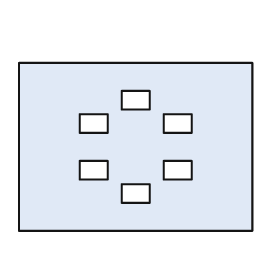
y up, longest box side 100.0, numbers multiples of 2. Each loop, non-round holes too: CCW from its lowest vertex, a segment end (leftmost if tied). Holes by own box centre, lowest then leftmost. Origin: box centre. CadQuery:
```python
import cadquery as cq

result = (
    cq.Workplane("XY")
    .moveTo(-50.0, -36.0)
    .lineTo(50.0, -36.0)
    .lineTo(50.0, 36.0)
    .lineTo(-50.0, 36.0)
    .close()
    .moveTo(-6.0, -24.0)
    .lineTo(6.0, -24.0)
    .lineTo(6.0, -16.0)
    .lineTo(-6.0, -16.0)
    .close()
    .moveTo(-24.0, -14.0)
    .lineTo(-12.0, -14.0)
    .lineTo(-12.0, -6.0)
    .lineTo(-24.0, -6.0)
    .close()
    .moveTo(12.0, -14.0)
    .lineTo(24.0, -14.0)
    .lineTo(24.0, -6.0)
    .lineTo(12.0, -6.0)
    .close()
    .moveTo(-24.0, 6.0)
    .lineTo(-12.0, 6.0)
    .lineTo(-12.0, 14.0)
    .lineTo(-24.0, 14.0)
    .close()
    .moveTo(12.0, 6.0)
    .lineTo(24.0, 6.0)
    .lineTo(24.0, 14.0)
    .lineTo(12.0, 14.0)
    .close()
    .moveTo(-6.0, 16.0)
    .lineTo(6.0, 16.0)
    .lineTo(6.0, 24.0)
    .lineTo(-6.0, 24.0)
    .close()
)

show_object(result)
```